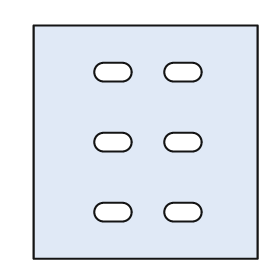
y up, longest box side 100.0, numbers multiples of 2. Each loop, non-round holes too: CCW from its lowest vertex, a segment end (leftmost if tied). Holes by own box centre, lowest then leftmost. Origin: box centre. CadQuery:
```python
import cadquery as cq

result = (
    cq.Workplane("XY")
    .moveTo(-48.0, -50.0)
    .lineTo(48.0, -50.0)
    .lineTo(48.0, 50.0)
    .lineTo(-48.0, 50.0)
    .close()
    .moveTo(-18.0, -34.0)
    .lineTo(-10.0, -34.0)
    .threePointArc((-6.0, -30.0), (-10.0, -26.0))
    .lineTo(-18.0, -26.0)
    .threePointArc((-22.0, -30.0), (-18.0, -34.0))
    .close()
    .moveTo(12.0, -34.0)
    .lineTo(20.0, -34.0)
    .threePointArc((24.0, -30.0), (20.0, -26.0))
    .lineTo(12.0, -26.0)
    .threePointArc((8.0, -30.0), (12.0, -34.0))
    .close()
    .moveTo(-18.0, -4.0)
    .lineTo(-10.0, -4.0)
    .threePointArc((-6.0, 0.0), (-10.0, 4.0))
    .lineTo(-18.0, 4.0)
    .threePointArc((-22.0, 0.0), (-18.0, -4.0))
    .close()
    .moveTo(12.0, -4.0)
    .lineTo(20.0, -4.0)
    .threePointArc((24.0, 0.0), (20.0, 4.0))
    .lineTo(12.0, 4.0)
    .threePointArc((8.0, 0.0), (12.0, -4.0))
    .close()
    .moveTo(-18.0, 26.0)
    .lineTo(-10.0, 26.0)
    .threePointArc((-6.0, 30.0), (-10.0, 34.0))
    .lineTo(-18.0, 34.0)
    .threePointArc((-22.0, 30.0), (-18.0, 26.0))
    .close()
    .moveTo(12.0, 26.0)
    .lineTo(20.0, 26.0)
    .threePointArc((24.0, 30.0), (20.0, 34.0))
    .lineTo(12.0, 34.0)
    .threePointArc((8.0, 30.0), (12.0, 26.0))
    .close()
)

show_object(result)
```